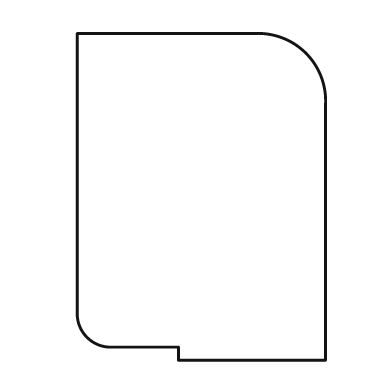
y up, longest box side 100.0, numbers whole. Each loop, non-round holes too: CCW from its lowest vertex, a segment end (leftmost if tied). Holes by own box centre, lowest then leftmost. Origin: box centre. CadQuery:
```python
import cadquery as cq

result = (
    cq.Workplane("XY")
    .moveTo(-7.0, -50.0)
    .lineTo(38.0, -50.0)
    .lineTo(38.0, 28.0)
    .threePointArc((32.0, 44.0), (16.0, 50.0))
    .lineTo(-38.0, 50.0)
    .lineTo(-38.0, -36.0)
    .threePointArc((-35.0, -43.0), (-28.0, -46.0))
    .lineTo(-7.0, -46.0)
    .close()
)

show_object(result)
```